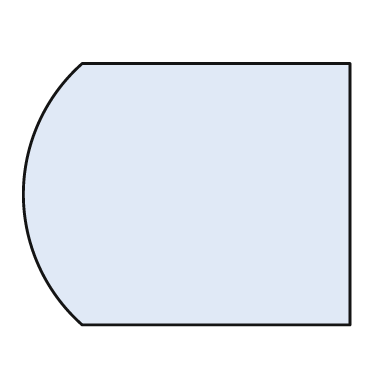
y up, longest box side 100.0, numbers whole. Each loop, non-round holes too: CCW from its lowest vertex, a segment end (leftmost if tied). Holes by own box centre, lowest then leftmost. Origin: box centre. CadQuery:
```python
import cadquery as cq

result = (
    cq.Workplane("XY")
    .moveTo(-32.0, -40.0)
    .lineTo(50.0, -40.0)
    .lineTo(50.0, 40.0)
    .lineTo(-32.0, 40.0)
    .threePointArc((-50.0, 0.0), (-32.0, -40.0))
    .close()
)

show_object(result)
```